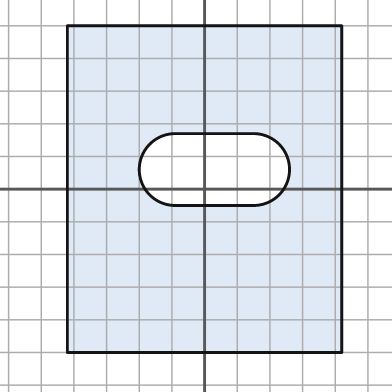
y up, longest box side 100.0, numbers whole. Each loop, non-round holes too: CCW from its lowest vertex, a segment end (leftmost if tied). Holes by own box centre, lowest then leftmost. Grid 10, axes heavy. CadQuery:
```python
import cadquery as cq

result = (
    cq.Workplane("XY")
    .moveTo(-42.0, -50.0)
    .lineTo(42.0, -50.0)
    .lineTo(42.0, 50.0)
    .lineTo(-42.0, 50.0)
    .close()
    .moveTo(-9.0, -5.0)
    .lineTo(15.0, -5.0)
    .threePointArc((26.0, 6.0), (15.0, 17.0))
    .lineTo(-9.0, 17.0)
    .threePointArc((-20.0, 6.0), (-9.0, -5.0))
    .close()
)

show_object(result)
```